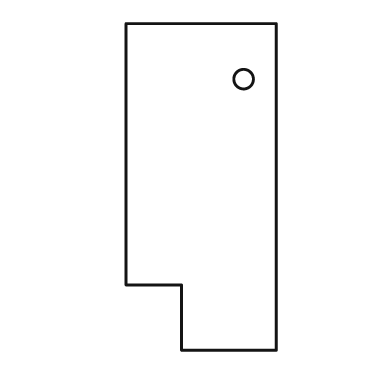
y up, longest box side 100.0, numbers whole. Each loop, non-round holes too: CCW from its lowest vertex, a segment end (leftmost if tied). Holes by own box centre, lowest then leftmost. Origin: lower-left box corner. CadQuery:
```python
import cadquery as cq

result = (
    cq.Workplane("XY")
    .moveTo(17.0, 0.0)
    .lineTo(46.0, 0.0)
    .lineTo(46.0, 100.0)
    .lineTo(0.0, 100.0)
    .lineTo(0.0, 20.0)
    .lineTo(17.0, 20.0)
    .close()
    .moveTo(36.0, 83.0)
    .circle(3.0)
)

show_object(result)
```